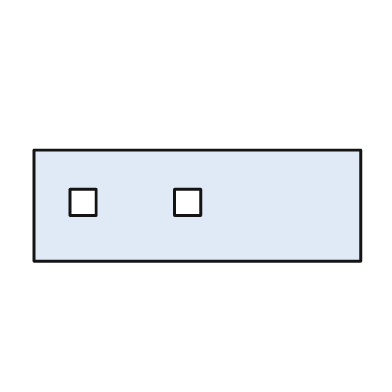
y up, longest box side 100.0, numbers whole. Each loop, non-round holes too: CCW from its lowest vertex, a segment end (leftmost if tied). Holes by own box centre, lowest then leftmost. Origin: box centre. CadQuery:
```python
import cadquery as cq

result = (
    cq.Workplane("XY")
    .moveTo(-50.0, -17.0)
    .lineTo(50.0, -17.0)
    .lineTo(50.0, 17.0)
    .lineTo(-50.0, 17.0)
    .close()
    .moveTo(-39.0, -3.0)
    .lineTo(-31.0, -3.0)
    .lineTo(-31.0, 5.0)
    .lineTo(-39.0, 5.0)
    .close()
    .moveTo(-7.0, -3.0)
    .lineTo(1.0, -3.0)
    .lineTo(1.0, 5.0)
    .lineTo(-7.0, 5.0)
    .close()
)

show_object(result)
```